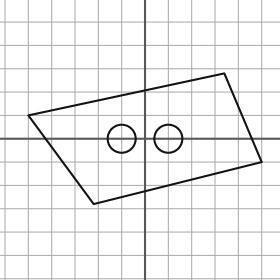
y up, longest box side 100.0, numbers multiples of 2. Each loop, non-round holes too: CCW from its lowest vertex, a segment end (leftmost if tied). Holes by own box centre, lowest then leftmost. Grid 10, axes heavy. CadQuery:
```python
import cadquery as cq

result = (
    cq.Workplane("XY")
    .moveTo(-22.0, -28.0)
    .lineTo(50.0, -10.0)
    .lineTo(34.0, 28.0)
    .lineTo(-50.0, 10.0)
    .close()
    .moveTo(-10.0, 0.0)
    .circle(6.0)
    .moveTo(10.0, 0.0)
    .circle(6.0)
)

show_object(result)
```